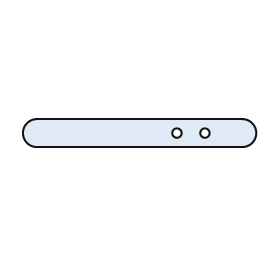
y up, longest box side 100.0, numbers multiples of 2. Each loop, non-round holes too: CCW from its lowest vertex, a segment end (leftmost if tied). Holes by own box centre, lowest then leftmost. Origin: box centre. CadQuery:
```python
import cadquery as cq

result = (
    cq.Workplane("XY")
    .moveTo(-44.0, -6.0)
    .lineTo(44.0, -6.0)
    .threePointArc((50.0, 0.0), (44.0, 6.0))
    .lineTo(-44.0, 6.0)
    .threePointArc((-50.0, 0.0), (-44.0, -6.0))
    .close()
    .moveTo(16.0, 0.0)
    .circle(2.0)
    .moveTo(28.0, 0.0)
    .circle(2.0)
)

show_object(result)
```